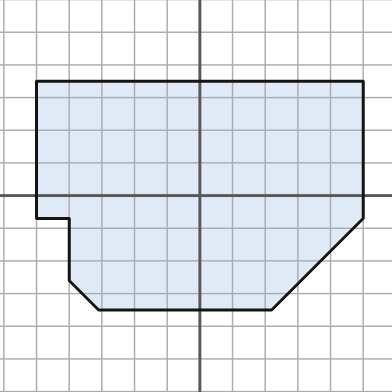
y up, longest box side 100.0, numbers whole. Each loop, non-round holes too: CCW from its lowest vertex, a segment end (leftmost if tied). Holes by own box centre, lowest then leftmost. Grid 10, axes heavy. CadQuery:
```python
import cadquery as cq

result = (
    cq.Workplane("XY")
    .moveTo(-31.0, -35.0)
    .lineTo(22.0, -35.0)
    .lineTo(50.0, -7.0)
    .lineTo(50.0, 35.0)
    .lineTo(-50.0, 35.0)
    .lineTo(-50.0, -7.0)
    .lineTo(-40.0, -7.0)
    .lineTo(-40.0, -26.0)
    .close()
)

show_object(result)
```